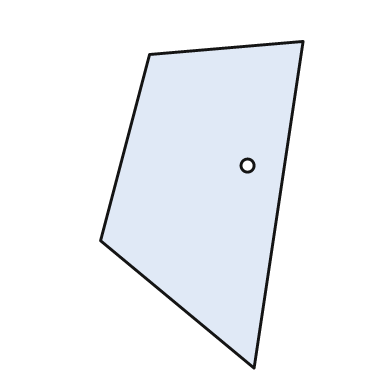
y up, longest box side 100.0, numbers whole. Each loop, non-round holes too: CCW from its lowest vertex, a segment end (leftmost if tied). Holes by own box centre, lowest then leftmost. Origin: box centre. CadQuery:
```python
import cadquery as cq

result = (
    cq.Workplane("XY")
    .moveTo(16.0, -50.0)
    .lineTo(31.0, 50.0)
    .lineTo(-16.0, 46.0)
    .lineTo(-31.0, -11.0)
    .close()
    .moveTo(14.0, 12.0)
    .circle(2.0)
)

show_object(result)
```